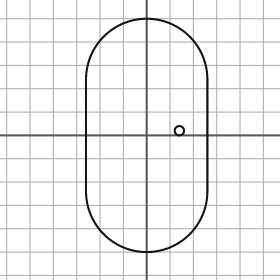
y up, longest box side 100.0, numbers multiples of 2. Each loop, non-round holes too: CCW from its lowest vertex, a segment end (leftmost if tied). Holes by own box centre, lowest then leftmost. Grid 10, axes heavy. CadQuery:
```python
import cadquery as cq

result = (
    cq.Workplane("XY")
    .moveTo(-26.0, -24.0)
    .threePointArc((0.0, -50.0), (26.0, -24.0))
    .lineTo(26.0, 24.0)
    .threePointArc((0.0, 50.0), (-26.0, 24.0))
    .close()
    .moveTo(14.0, 2.0)
    .circle(2.0)
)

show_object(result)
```